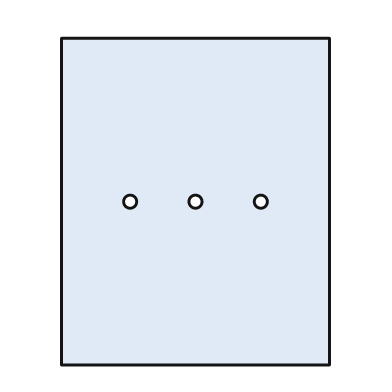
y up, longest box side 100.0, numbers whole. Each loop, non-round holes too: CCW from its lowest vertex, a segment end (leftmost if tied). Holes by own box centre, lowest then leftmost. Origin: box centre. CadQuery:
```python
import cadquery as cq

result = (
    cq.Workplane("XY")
    .moveTo(-41.0, -50.0)
    .lineTo(41.0, -50.0)
    .lineTo(41.0, 50.0)
    .lineTo(-41.0, 50.0)
    .close()
    .moveTo(-20.0, 0.0)
    .circle(2.0)
    .moveTo(0.0, 0.0)
    .circle(2.0)
    .moveTo(20.0, 0.0)
    .circle(2.0)
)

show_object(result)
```